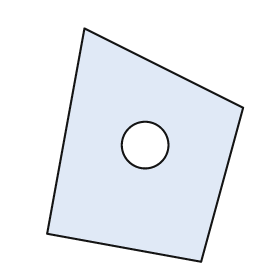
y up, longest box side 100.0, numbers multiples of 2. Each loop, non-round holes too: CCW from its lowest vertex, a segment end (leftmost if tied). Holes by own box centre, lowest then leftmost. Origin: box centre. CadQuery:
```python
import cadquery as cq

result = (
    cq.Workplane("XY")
    .moveTo(24.0, -50.0)
    .lineTo(42.0, 16.0)
    .lineTo(-26.0, 50.0)
    .lineTo(-42.0, -38.0)
    .close()
    .moveTo(0.0, 0.0)
    .circle(10.0)
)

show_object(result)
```